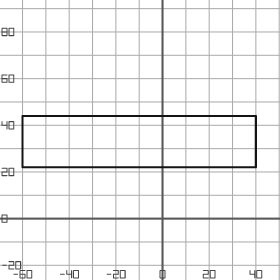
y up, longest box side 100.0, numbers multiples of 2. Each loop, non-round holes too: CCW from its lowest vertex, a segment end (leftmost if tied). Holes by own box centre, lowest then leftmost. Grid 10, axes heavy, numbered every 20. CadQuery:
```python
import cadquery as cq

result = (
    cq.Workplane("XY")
    .moveTo(-60.0, 22.0)
    .lineTo(40.0, 22.0)
    .lineTo(40.0, 44.0)
    .lineTo(-60.0, 44.0)
    .close()
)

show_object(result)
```